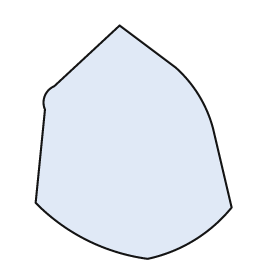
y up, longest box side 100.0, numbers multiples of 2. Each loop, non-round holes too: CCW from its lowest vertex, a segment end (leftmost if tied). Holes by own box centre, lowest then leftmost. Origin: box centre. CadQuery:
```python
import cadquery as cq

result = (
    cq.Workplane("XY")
    .moveTo(6.0, -50.0)
    .threePointArc((26.0, -42.0), (42.0, -28.0))
    .lineTo(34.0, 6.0)
    .threePointArc((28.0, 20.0), (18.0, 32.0))
    .lineTo(-6.0, 50.0)
    .lineTo(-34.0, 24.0)
    .threePointArc((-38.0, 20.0), (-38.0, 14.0))
    .lineTo(-42.0, -26.0)
    .threePointArc((-20.0, -42.0), (6.0, -50.0))
    .close()
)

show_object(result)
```